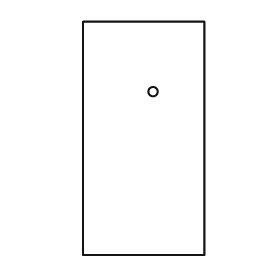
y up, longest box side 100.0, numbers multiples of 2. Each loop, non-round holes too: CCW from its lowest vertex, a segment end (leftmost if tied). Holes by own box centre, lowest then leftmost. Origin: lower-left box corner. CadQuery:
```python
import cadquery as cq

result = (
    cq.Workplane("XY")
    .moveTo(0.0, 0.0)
    .lineTo(52.0, 0.0)
    .lineTo(52.0, 100.0)
    .lineTo(0.0, 100.0)
    .close()
    .moveTo(30.0, 70.0)
    .circle(2.0)
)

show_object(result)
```